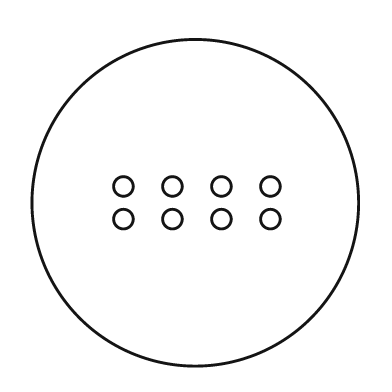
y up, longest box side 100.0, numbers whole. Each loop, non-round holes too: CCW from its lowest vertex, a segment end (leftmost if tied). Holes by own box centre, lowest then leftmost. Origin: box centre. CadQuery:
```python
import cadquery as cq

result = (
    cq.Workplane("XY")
    .moveTo(0.0, 0.0)
    .circle(50.0)
    .moveTo(-22.0, -5.0)
    .circle(3.0)
    .moveTo(-7.0, -5.0)
    .circle(3.0)
    .moveTo(8.0, -5.0)
    .circle(3.0)
    .moveTo(23.0, -5.0)
    .circle(3.0)
    .moveTo(-22.0, 5.0)
    .circle(3.0)
    .moveTo(-7.0, 5.0)
    .circle(3.0)
    .moveTo(8.0, 5.0)
    .circle(3.0)
    .moveTo(23.0, 5.0)
    .circle(3.0)
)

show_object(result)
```